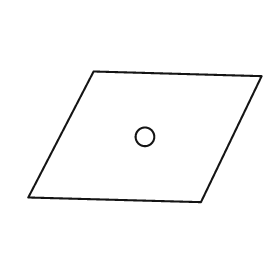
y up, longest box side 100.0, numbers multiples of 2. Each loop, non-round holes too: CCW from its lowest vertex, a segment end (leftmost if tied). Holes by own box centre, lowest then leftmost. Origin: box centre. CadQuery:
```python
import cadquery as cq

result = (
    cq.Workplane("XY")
    .moveTo(24.0, -28.0)
    .lineTo(50.0, 26.0)
    .lineTo(-22.0, 28.0)
    .lineTo(-50.0, -26.0)
    .close()
    .moveTo(0.0, 0.0)
    .circle(4.0)
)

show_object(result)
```